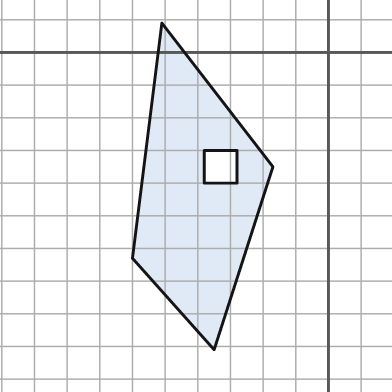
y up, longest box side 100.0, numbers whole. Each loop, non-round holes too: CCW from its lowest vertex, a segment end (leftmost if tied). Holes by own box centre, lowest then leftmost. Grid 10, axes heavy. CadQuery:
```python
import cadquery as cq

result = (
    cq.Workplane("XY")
    .moveTo(-35.0, -91.0)
    .lineTo(-17.0, -35.0)
    .lineTo(-51.0, 9.0)
    .lineTo(-60.0, -63.0)
    .close()
    .moveTo(-38.0, -40.0)
    .lineTo(-28.0, -40.0)
    .lineTo(-28.0, -30.0)
    .lineTo(-38.0, -30.0)
    .close()
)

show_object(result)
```